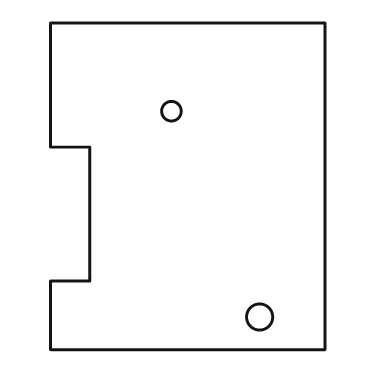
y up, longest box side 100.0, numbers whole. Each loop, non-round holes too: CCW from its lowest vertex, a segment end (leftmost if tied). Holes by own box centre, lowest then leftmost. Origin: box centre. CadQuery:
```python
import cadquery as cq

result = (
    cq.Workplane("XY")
    .moveTo(-42.0, -50.0)
    .lineTo(42.0, -50.0)
    .lineTo(42.0, 50.0)
    .lineTo(-42.0, 50.0)
    .lineTo(-42.0, 12.0)
    .lineTo(-30.0, 12.0)
    .lineTo(-30.0, -29.0)
    .lineTo(-42.0, -29.0)
    .close()
    .moveTo(22.0, -40.0)
    .circle(4.0)
    .moveTo(-5.0, 23.0)
    .circle(3.0)
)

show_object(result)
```